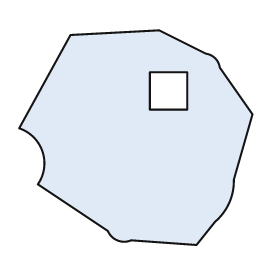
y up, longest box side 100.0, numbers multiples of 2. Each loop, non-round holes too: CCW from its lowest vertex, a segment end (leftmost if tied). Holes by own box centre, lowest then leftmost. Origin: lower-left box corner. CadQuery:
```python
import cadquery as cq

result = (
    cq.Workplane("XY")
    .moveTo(76.0, 0.0)
    .lineTo(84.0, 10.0)
    .threePointArc((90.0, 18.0), (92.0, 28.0))
    .lineTo(100.0, 56.0)
    .lineTo(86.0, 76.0)
    .threePointArc((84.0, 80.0), (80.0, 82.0))
    .lineTo(60.0, 92.0)
    .lineTo(22.0, 90.0)
    .lineTo(0.0, 50.0)
    .threePointArc((10.0, 40.0), (8.0, 26.0))
    .lineTo(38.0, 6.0)
    .threePointArc((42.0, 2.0), (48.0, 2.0))
    .close()
    .moveTo(56.0, 58.0)
    .lineTo(72.0, 58.0)
    .lineTo(72.0, 74.0)
    .lineTo(56.0, 74.0)
    .close()
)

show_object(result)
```